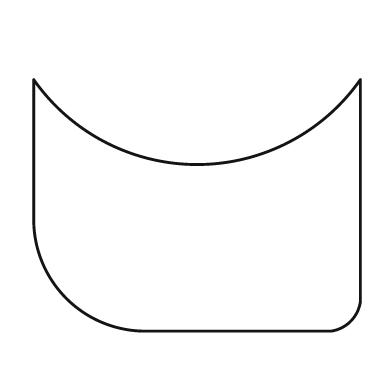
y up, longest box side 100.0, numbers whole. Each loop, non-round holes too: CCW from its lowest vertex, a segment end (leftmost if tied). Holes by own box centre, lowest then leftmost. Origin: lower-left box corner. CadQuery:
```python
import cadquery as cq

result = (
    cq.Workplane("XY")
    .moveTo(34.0, 0.0)
    .lineTo(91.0, 0.0)
    .threePointArc((97.0, 3.0), (100.0, 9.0))
    .lineTo(100.0, 77.0)
    .threePointArc((50.0, 51.0), (0.0, 77.0))
    .lineTo(0.0, 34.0)
    .threePointArc((10.0, 10.0), (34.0, 0.0))
    .close()
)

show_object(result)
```